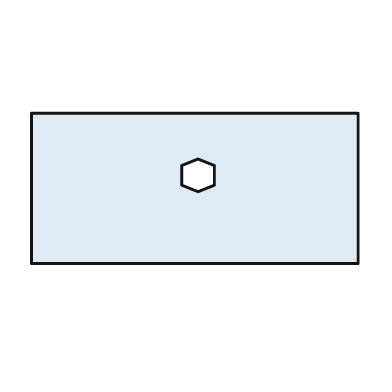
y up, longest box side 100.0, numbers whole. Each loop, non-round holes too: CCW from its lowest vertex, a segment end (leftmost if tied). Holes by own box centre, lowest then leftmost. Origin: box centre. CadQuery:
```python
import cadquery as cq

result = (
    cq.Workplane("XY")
    .moveTo(-50.0, -23.0)
    .lineTo(50.0, -23.0)
    .lineTo(50.0, 23.0)
    .lineTo(-50.0, 23.0)
    .close()
    .moveTo(1.0, -1.0)
    .lineTo(6.0, 1.0)
    .lineTo(6.0, 7.0)
    .lineTo(1.0, 9.0)
    .lineTo(-4.0, 7.0)
    .lineTo(-4.0, 1.0)
    .close()
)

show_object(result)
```